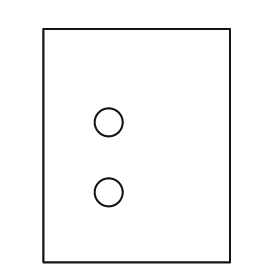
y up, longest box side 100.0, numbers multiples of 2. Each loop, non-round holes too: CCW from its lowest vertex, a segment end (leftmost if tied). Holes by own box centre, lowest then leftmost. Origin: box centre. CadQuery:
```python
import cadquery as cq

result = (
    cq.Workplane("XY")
    .moveTo(-40.0, -50.0)
    .lineTo(40.0, -50.0)
    .lineTo(40.0, 50.0)
    .lineTo(-40.0, 50.0)
    .close()
    .moveTo(-12.0, -20.0)
    .circle(6.0)
    .moveTo(-12.0, 10.0)
    .circle(6.0)
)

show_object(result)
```